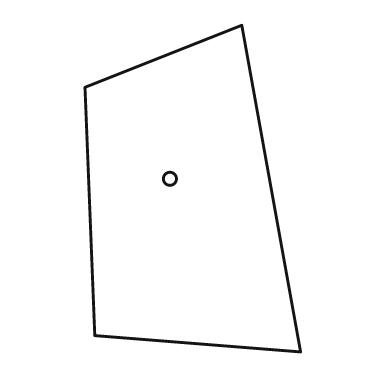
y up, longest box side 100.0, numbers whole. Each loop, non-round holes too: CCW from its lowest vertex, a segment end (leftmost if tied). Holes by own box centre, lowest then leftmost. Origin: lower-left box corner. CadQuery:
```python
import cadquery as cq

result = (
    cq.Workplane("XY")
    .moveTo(66.0, 0.0)
    .lineTo(48.0, 100.0)
    .lineTo(0.0, 81.0)
    .lineTo(3.0, 5.0)
    .close()
    .moveTo(26.0, 53.0)
    .circle(2.0)
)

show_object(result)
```